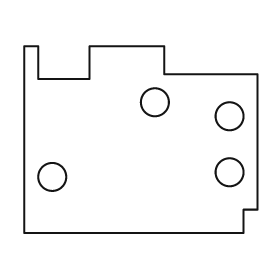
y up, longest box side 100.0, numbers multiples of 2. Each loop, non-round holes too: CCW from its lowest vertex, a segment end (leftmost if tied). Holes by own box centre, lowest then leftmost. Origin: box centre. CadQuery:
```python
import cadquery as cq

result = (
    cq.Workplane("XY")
    .moveTo(-50.0, -40.0)
    .lineTo(44.0, -40.0)
    .lineTo(44.0, -30.0)
    .lineTo(50.0, -30.0)
    .lineTo(50.0, 28.0)
    .lineTo(10.0, 28.0)
    .lineTo(10.0, 40.0)
    .lineTo(-22.0, 40.0)
    .lineTo(-22.0, 26.0)
    .lineTo(-44.0, 26.0)
    .lineTo(-44.0, 40.0)
    .lineTo(-50.0, 40.0)
    .close()
    .moveTo(-38.0, -16.0)
    .circle(6.0)
    .moveTo(38.0, -14.0)
    .circle(6.0)
    .moveTo(38.0, 10.0)
    .circle(6.0)
    .moveTo(6.0, 16.0)
    .circle(6.0)
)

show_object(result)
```